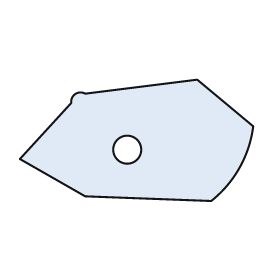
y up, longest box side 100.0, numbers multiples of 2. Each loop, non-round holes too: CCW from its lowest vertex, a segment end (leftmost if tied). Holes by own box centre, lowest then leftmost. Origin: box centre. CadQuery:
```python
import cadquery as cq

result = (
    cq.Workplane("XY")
    .moveTo(32.0, -26.0)
    .threePointArc((44.0, -12.0), (50.0, 6.0))
    .lineTo(26.0, 26.0)
    .lineTo(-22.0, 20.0)
    .threePointArc((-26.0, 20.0), (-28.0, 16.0))
    .lineTo(-50.0, -8.0)
    .lineTo(-22.0, -24.0)
    .close()
    .moveTo(-4.0, -4.0)
    .circle(6.0)
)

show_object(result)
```